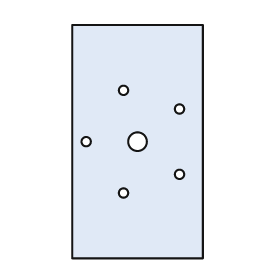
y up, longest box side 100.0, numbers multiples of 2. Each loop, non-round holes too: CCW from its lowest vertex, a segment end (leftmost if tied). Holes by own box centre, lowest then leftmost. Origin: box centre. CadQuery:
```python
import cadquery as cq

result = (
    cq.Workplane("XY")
    .moveTo(-28.0, -50.0)
    .lineTo(28.0, -50.0)
    .lineTo(28.0, 50.0)
    .lineTo(-28.0, 50.0)
    .close()
    .moveTo(-6.0, -22.0)
    .circle(2.0)
    .moveTo(18.0, -14.0)
    .circle(2.0)
    .moveTo(-22.0, 0.0)
    .circle(2.0)
    .moveTo(0.0, 0.0)
    .circle(4.0)
    .moveTo(18.0, 14.0)
    .circle(2.0)
    .moveTo(-6.0, 22.0)
    .circle(2.0)
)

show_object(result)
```